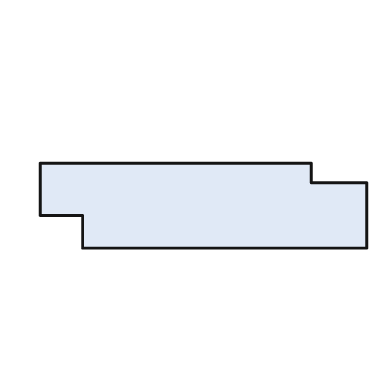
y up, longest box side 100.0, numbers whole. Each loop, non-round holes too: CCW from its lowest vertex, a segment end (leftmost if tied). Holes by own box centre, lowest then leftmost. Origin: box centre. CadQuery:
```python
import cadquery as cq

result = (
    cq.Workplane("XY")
    .moveTo(-37.0, -13.0)
    .lineTo(50.0, -13.0)
    .lineTo(50.0, 7.0)
    .lineTo(33.0, 7.0)
    .lineTo(33.0, 13.0)
    .lineTo(-50.0, 13.0)
    .lineTo(-50.0, -3.0)
    .lineTo(-37.0, -3.0)
    .close()
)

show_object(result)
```